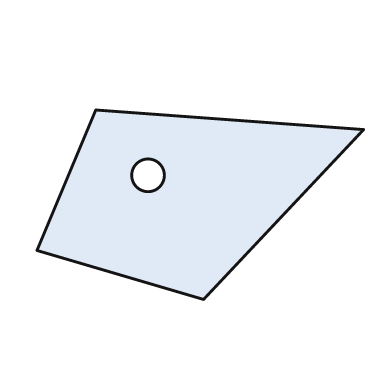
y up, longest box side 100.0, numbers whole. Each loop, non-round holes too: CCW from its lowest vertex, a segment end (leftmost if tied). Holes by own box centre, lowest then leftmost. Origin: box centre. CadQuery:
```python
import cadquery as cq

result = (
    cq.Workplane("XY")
    .moveTo(1.0, -29.0)
    .lineTo(50.0, 23.0)
    .lineTo(-32.0, 29.0)
    .lineTo(-50.0, -14.0)
    .close()
    .moveTo(-16.0, 9.0)
    .circle(5.0)
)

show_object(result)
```